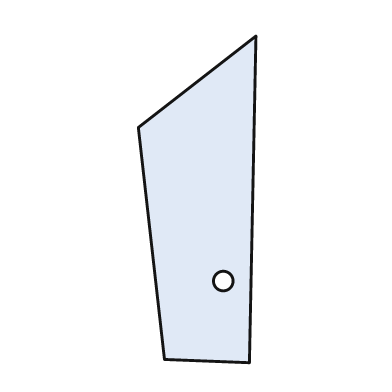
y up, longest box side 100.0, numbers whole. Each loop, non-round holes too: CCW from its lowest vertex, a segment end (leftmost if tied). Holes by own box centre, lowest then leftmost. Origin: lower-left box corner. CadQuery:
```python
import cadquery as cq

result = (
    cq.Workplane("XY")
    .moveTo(34.0, 0.0)
    .lineTo(36.0, 100.0)
    .lineTo(0.0, 72.0)
    .lineTo(8.0, 1.0)
    .close()
    .moveTo(26.0, 25.0)
    .circle(3.0)
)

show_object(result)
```